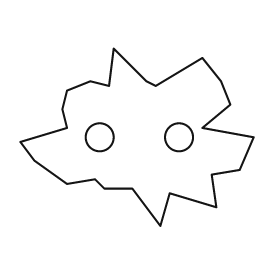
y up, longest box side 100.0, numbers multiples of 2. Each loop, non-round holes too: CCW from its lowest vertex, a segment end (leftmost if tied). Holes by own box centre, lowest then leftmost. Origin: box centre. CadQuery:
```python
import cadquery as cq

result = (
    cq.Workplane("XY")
    .moveTo(10.0, -38.0)
    .lineTo(14.0, -24.0)
    .lineTo(34.0, -30.0)
    .lineTo(32.0, -16.0)
    .lineTo(44.0, -14.0)
    .lineTo(50.0, 0.0)
    .lineTo(28.0, 4.0)
    .lineTo(40.0, 14.0)
    .lineTo(36.0, 24.0)
    .lineTo(28.0, 34.0)
    .lineTo(8.0, 22.0)
    .lineTo(4.0, 24.0)
    .lineTo(-10.0, 38.0)
    .lineTo(-12.0, 22.0)
    .lineTo(-20.0, 24.0)
    .lineTo(-30.0, 20.0)
    .lineTo(-32.0, 12.0)
    .lineTo(-30.0, 4.0)
    .lineTo(-50.0, -2.0)
    .lineTo(-44.0, -10.0)
    .lineTo(-30.0, -20.0)
    .lineTo(-18.0, -18.0)
    .lineTo(-14.0, -22.0)
    .lineTo(-2.0, -22.0)
    .close()
    .moveTo(-16.0, 0.0)
    .circle(6.0)
    .moveTo(18.0, 0.0)
    .circle(6.0)
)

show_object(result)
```